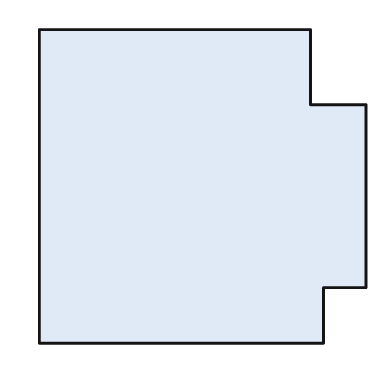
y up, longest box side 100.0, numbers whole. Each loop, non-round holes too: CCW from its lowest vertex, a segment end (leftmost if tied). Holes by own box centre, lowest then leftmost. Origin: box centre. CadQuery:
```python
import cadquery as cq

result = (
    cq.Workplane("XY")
    .moveTo(-50.0, -48.0)
    .lineTo(37.0, -48.0)
    .lineTo(37.0, -31.0)
    .lineTo(50.0, -31.0)
    .lineTo(50.0, 25.0)
    .lineTo(33.0, 25.0)
    .lineTo(33.0, 48.0)
    .lineTo(-50.0, 48.0)
    .close()
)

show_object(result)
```